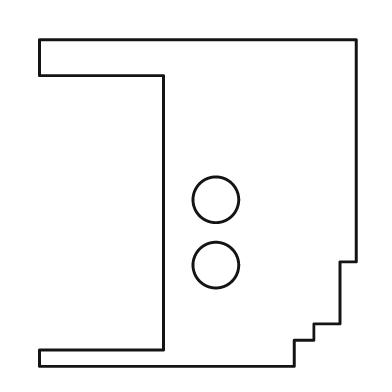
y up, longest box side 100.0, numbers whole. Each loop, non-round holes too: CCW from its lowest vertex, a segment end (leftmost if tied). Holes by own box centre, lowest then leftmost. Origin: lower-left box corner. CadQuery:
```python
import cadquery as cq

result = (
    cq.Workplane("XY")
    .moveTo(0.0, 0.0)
    .lineTo(78.0, 0.0)
    .lineTo(78.0, 8.0)
    .lineTo(84.0, 8.0)
    .lineTo(84.0, 13.0)
    .lineTo(92.0, 13.0)
    .lineTo(92.0, 32.0)
    .lineTo(97.0, 32.0)
    .lineTo(97.0, 100.0)
    .lineTo(0.0, 100.0)
    .lineTo(0.0, 89.0)
    .lineTo(38.0, 89.0)
    .lineTo(38.0, 5.0)
    .lineTo(0.0, 5.0)
    .close()
    .moveTo(54.0, 31.0)
    .circle(7.0)
    .moveTo(54.0, 51.0)
    .circle(7.0)
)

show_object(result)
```